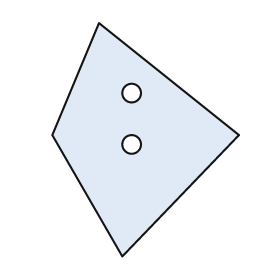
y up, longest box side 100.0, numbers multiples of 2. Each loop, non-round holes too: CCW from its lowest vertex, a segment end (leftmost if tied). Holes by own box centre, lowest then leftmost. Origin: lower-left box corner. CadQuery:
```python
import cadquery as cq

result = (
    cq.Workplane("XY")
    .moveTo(30.0, 0.0)
    .lineTo(80.0, 52.0)
    .lineTo(20.0, 100.0)
    .lineTo(0.0, 52.0)
    .close()
    .moveTo(34.0, 48.0)
    .circle(4.0)
    .moveTo(34.0, 70.0)
    .circle(4.0)
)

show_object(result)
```